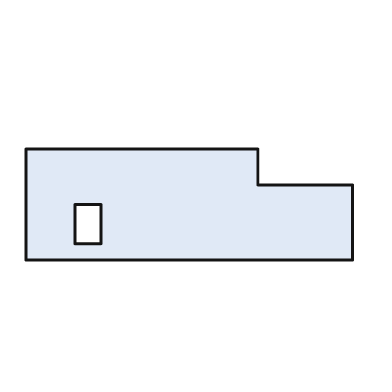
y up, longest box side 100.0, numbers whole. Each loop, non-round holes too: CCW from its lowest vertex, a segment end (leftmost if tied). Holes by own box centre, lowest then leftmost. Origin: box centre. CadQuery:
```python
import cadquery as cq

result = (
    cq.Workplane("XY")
    .moveTo(-50.0, -17.0)
    .lineTo(50.0, -17.0)
    .lineTo(50.0, 6.0)
    .lineTo(21.0, 6.0)
    .lineTo(21.0, 17.0)
    .lineTo(-50.0, 17.0)
    .close()
    .moveTo(-35.0, -12.0)
    .lineTo(-27.0, -12.0)
    .lineTo(-27.0, 0.0)
    .lineTo(-35.0, 0.0)
    .close()
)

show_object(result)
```